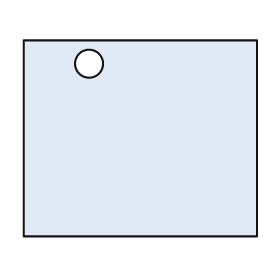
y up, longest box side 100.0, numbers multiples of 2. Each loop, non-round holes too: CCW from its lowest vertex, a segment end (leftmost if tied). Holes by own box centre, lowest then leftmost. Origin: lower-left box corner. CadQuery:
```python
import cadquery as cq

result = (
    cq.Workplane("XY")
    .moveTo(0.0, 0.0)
    .lineTo(100.0, 0.0)
    .lineTo(100.0, 84.0)
    .lineTo(0.0, 84.0)
    .close()
    .moveTo(28.0, 74.0)
    .circle(6.0)
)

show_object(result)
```